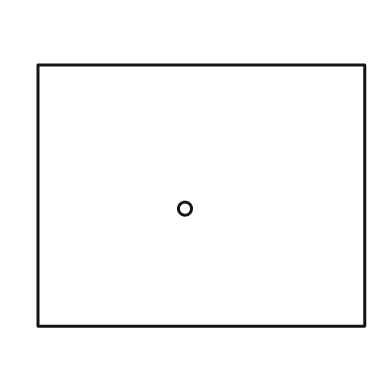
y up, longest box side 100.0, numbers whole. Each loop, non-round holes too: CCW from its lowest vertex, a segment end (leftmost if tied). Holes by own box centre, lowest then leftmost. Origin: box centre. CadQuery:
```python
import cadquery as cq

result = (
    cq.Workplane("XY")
    .moveTo(-50.0, -40.0)
    .lineTo(50.0, -40.0)
    .lineTo(50.0, 40.0)
    .lineTo(-50.0, 40.0)
    .close()
    .moveTo(-5.0, -4.0)
    .circle(2.0)
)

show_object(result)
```